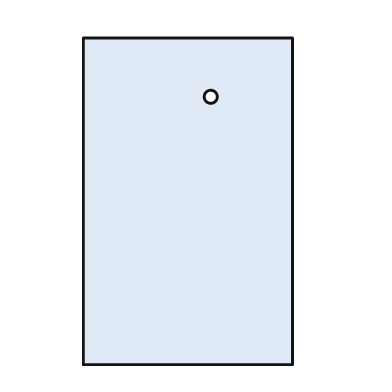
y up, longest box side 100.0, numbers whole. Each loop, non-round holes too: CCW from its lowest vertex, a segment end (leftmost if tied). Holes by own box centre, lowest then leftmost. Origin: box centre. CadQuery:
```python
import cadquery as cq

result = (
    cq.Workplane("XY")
    .moveTo(-32.0, -50.0)
    .lineTo(32.0, -50.0)
    .lineTo(32.0, 50.0)
    .lineTo(-32.0, 50.0)
    .close()
    .moveTo(7.0, 32.0)
    .circle(2.0)
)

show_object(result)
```